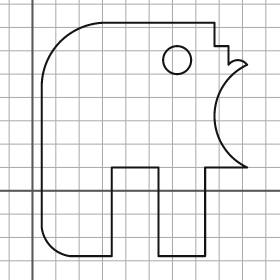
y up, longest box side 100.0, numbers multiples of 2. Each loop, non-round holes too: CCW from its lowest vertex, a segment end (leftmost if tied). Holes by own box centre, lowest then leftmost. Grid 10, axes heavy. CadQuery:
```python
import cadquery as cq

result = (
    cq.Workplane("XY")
    .moveTo(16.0, -28.0)
    .lineTo(34.0, -28.0)
    .lineTo(34.0, 10.0)
    .lineTo(54.0, 10.0)
    .lineTo(54.0, -28.0)
    .lineTo(74.0, -28.0)
    .lineTo(74.0, 10.0)
    .lineTo(92.0, 10.0)
    .threePointArc((78.0, 32.0), (92.0, 54.0))
    .threePointArc((88.0, 56.0), (84.0, 54.0))
    .lineTo(84.0, 62.0)
    .lineTo(78.0, 62.0)
    .lineTo(78.0, 72.0)
    .lineTo(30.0, 72.0)
    .threePointArc((12.0, 64.0), (4.0, 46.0))
    .lineTo(4.0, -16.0)
    .threePointArc((8.0, -24.0), (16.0, -28.0))
    .close()
    .moveTo(62.0, 56.0)
    .circle(6.0)
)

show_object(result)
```